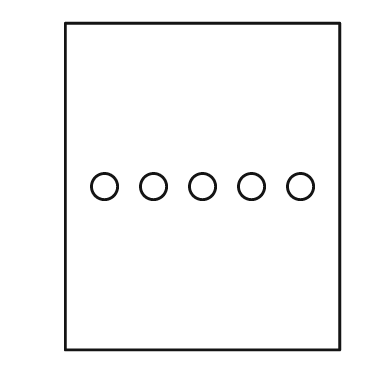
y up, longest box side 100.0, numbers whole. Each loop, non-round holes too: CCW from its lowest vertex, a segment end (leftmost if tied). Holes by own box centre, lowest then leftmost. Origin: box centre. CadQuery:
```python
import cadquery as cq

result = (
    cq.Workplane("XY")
    .moveTo(-42.0, -50.0)
    .lineTo(42.0, -50.0)
    .lineTo(42.0, 50.0)
    .lineTo(-42.0, 50.0)
    .close()
    .moveTo(-30.0, 0.0)
    .circle(4.0)
    .moveTo(-15.0, 0.0)
    .circle(4.0)
    .moveTo(0.0, 0.0)
    .circle(4.0)
    .moveTo(15.0, 0.0)
    .circle(4.0)
    .moveTo(30.0, 0.0)
    .circle(4.0)
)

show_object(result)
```